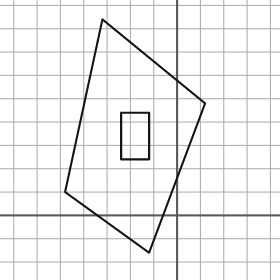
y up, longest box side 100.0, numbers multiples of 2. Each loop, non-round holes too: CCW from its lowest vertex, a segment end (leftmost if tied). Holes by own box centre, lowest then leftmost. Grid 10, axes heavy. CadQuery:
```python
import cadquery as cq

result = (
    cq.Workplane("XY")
    .moveTo(-12.0, -16.0)
    .lineTo(12.0, 48.0)
    .lineTo(-32.0, 84.0)
    .lineTo(-48.0, 10.0)
    .close()
    .moveTo(-24.0, 24.0)
    .lineTo(-12.0, 24.0)
    .lineTo(-12.0, 44.0)
    .lineTo(-24.0, 44.0)
    .close()
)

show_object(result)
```